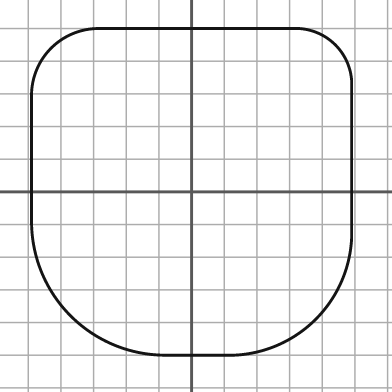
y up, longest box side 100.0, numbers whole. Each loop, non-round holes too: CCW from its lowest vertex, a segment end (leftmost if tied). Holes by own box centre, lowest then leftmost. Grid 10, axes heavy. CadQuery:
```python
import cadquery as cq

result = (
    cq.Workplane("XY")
    .moveTo(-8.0, -50.0)
    .lineTo(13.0, -50.0)
    .threePointArc((38.0, -39.0), (49.0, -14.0))
    .lineTo(49.0, 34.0)
    .threePointArc((44.0, 45.0), (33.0, 50.0))
    .lineTo(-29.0, 50.0)
    .threePointArc((-43.0, 44.0), (-49.0, 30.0))
    .lineTo(-49.0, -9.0)
    .threePointArc((-37.0, -38.0), (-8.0, -50.0))
    .close()
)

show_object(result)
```